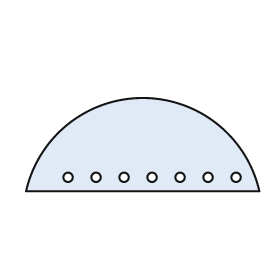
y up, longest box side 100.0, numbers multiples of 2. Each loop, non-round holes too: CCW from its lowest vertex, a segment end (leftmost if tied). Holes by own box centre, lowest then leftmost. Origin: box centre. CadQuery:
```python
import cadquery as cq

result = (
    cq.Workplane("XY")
    .moveTo(-50.0, -20.0)
    .lineTo(50.0, -20.0)
    .threePointArc((0.0, 20.0), (-50.0, -20.0))
    .close()
    .moveTo(-32.0, -14.0)
    .circle(2.0)
    .moveTo(-20.0, -14.0)
    .circle(2.0)
    .moveTo(-8.0, -14.0)
    .circle(2.0)
    .moveTo(4.0, -14.0)
    .circle(2.0)
    .moveTo(16.0, -14.0)
    .circle(2.0)
    .moveTo(28.0, -14.0)
    .circle(2.0)
    .moveTo(40.0, -14.0)
    .circle(2.0)
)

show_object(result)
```